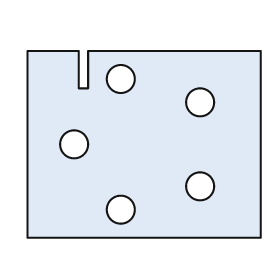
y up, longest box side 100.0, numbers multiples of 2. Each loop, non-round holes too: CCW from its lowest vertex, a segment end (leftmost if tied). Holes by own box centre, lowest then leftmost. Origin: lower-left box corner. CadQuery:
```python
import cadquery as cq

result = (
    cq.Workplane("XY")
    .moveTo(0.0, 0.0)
    .lineTo(100.0, 0.0)
    .lineTo(100.0, 80.0)
    .lineTo(26.0, 80.0)
    .lineTo(26.0, 64.0)
    .lineTo(22.0, 64.0)
    .lineTo(22.0, 80.0)
    .lineTo(0.0, 80.0)
    .close()
    .moveTo(40.0, 12.0)
    .circle(6.0)
    .moveTo(74.0, 22.0)
    .circle(6.0)
    .moveTo(20.0, 40.0)
    .circle(6.0)
    .moveTo(74.0, 58.0)
    .circle(6.0)
    .moveTo(40.0, 68.0)
    .circle(6.0)
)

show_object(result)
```